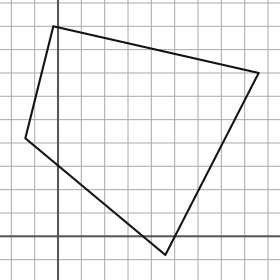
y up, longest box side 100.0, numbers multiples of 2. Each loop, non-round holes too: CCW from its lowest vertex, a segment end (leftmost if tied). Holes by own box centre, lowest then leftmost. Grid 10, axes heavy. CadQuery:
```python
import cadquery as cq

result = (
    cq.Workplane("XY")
    .moveTo(46.0, -8.0)
    .lineTo(86.0, 70.0)
    .lineTo(-2.0, 90.0)
    .lineTo(-14.0, 42.0)
    .close()
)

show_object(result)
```